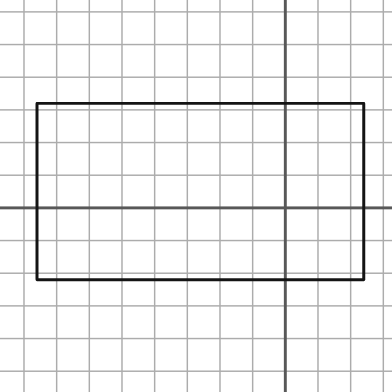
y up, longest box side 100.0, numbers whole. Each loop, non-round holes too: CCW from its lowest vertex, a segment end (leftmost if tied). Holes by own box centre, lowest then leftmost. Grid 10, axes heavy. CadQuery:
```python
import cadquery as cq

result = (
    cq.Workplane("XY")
    .moveTo(-76.0, -22.0)
    .lineTo(24.0, -22.0)
    .lineTo(24.0, 32.0)
    .lineTo(-76.0, 32.0)
    .close()
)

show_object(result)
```